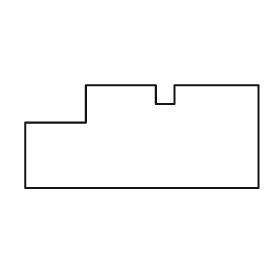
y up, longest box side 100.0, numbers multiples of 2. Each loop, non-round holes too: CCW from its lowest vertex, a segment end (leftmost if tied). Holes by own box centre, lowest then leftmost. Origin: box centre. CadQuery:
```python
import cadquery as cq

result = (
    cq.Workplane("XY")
    .moveTo(-50.0, -22.0)
    .lineTo(50.0, -22.0)
    .lineTo(50.0, 22.0)
    .lineTo(14.0, 22.0)
    .lineTo(14.0, 14.0)
    .lineTo(6.0, 14.0)
    .lineTo(6.0, 22.0)
    .lineTo(-24.0, 22.0)
    .lineTo(-24.0, 6.0)
    .lineTo(-50.0, 6.0)
    .close()
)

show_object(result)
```